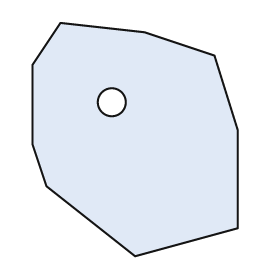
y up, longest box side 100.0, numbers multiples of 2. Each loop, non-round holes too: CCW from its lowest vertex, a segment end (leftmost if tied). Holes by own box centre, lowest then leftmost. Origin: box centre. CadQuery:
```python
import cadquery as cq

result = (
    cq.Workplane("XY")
    .moveTo(0.0, -50.0)
    .lineTo(44.0, -38.0)
    .lineTo(44.0, 4.0)
    .lineTo(34.0, 36.0)
    .lineTo(4.0, 46.0)
    .lineTo(-32.0, 50.0)
    .lineTo(-44.0, 32.0)
    .lineTo(-44.0, -2.0)
    .lineTo(-38.0, -20.0)
    .close()
    .moveTo(-10.0, 16.0)
    .circle(6.0)
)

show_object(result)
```